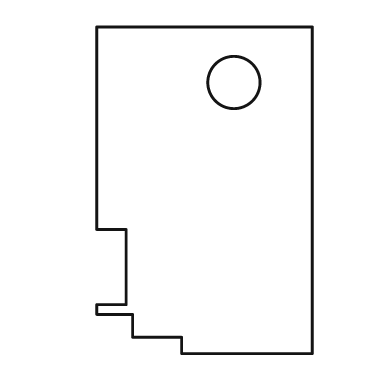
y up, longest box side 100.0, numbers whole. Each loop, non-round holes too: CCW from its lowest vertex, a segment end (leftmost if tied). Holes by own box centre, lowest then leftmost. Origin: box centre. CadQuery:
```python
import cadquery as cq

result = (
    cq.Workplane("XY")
    .moveTo(-7.0, -50.0)
    .lineTo(33.0, -50.0)
    .lineTo(33.0, 50.0)
    .lineTo(-33.0, 50.0)
    .lineTo(-33.0, -12.0)
    .lineTo(-24.0, -12.0)
    .lineTo(-24.0, -35.0)
    .lineTo(-33.0, -35.0)
    .lineTo(-33.0, -38.0)
    .lineTo(-22.0, -38.0)
    .lineTo(-22.0, -45.0)
    .lineTo(-7.0, -45.0)
    .close()
    .moveTo(9.0, 33.0)
    .circle(8.0)
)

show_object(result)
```